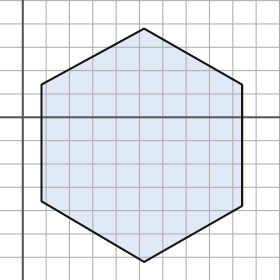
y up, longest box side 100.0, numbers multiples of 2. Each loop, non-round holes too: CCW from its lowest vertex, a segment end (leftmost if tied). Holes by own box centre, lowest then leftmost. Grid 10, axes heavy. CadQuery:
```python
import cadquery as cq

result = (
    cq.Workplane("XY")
    .moveTo(52.0, -62.0)
    .lineTo(94.0, -38.0)
    .lineTo(94.0, 14.0)
    .lineTo(52.0, 38.0)
    .lineTo(8.0, 14.0)
    .lineTo(8.0, -36.0)
    .close()
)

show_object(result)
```